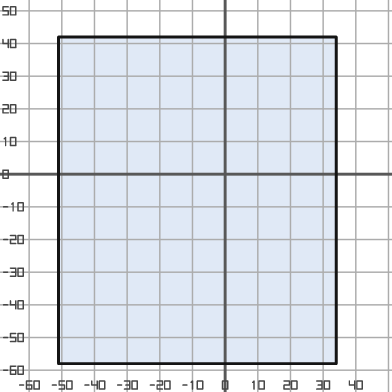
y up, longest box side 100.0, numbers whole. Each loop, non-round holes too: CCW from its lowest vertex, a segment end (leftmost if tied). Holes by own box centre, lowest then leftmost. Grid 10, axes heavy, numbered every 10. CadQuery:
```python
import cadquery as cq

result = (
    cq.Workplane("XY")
    .moveTo(-51.0, -58.0)
    .lineTo(34.0, -58.0)
    .lineTo(34.0, 42.0)
    .lineTo(-51.0, 42.0)
    .close()
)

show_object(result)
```